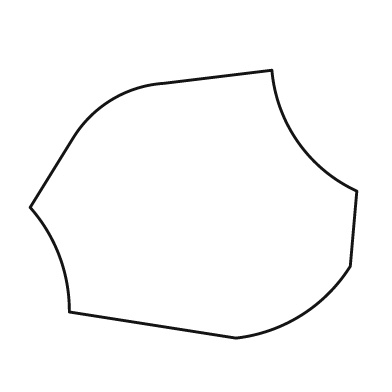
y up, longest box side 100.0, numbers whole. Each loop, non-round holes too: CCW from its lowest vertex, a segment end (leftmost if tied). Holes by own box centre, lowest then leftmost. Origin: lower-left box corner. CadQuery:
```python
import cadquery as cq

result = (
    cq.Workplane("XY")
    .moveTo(63.0, 0.0)
    .threePointArc((83.0, 7.0), (98.0, 22.0))
    .lineTo(100.0, 45.0)
    .threePointArc((82.0, 60.0), (74.0, 82.0))
    .lineTo(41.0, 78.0)
    .threePointArc((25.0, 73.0), (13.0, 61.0))
    .lineTo(0.0, 40.0)
    .threePointArc((9.0, 25.0), (12.0, 8.0))
    .close()
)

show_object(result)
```